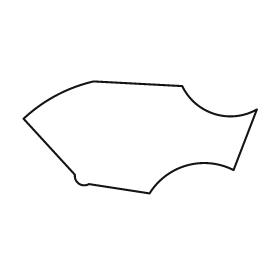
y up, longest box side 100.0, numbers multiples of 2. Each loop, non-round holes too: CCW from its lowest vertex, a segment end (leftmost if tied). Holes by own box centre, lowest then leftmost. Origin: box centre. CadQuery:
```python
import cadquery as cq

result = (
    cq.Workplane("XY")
    .moveTo(4.0, -24.0)
    .threePointArc((20.0, -12.0), (40.0, -14.0))
    .lineTo(50.0, 12.0)
    .threePointArc((32.0, 10.0), (18.0, 22.0))
    .lineTo(-20.0, 24.0)
    .threePointArc((-36.0, 18.0), (-50.0, 8.0))
    .lineTo(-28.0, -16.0)
    .threePointArc((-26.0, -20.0), (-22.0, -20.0))
    .close()
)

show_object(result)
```